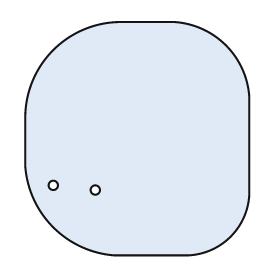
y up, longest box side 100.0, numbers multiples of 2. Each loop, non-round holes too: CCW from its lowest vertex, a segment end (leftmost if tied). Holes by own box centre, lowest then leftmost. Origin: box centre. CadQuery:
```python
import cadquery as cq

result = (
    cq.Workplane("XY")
    .moveTo(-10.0, -50.0)
    .lineTo(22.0, -50.0)
    .threePointArc((40.0, -42.0), (48.0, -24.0))
    .lineTo(48.0, 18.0)
    .threePointArc((38.0, 40.0), (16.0, 50.0))
    .lineTo(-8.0, 50.0)
    .threePointArc((-36.0, 38.0), (-48.0, 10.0))
    .lineTo(-48.0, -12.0)
    .threePointArc((-36.0, -38.0), (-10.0, -50.0))
    .close()
    .moveTo(-18.0, -22.0)
    .circle(2.0)
    .moveTo(-36.0, -20.0)
    .circle(2.0)
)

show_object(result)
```